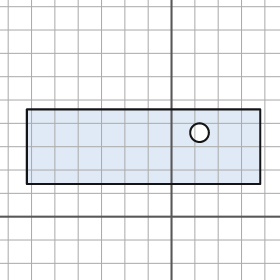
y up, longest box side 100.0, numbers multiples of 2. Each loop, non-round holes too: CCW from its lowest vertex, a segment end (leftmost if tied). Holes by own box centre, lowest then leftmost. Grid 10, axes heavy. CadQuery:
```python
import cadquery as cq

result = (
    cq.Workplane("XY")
    .moveTo(-62.0, 14.0)
    .lineTo(38.0, 14.0)
    .lineTo(38.0, 46.0)
    .lineTo(-62.0, 46.0)
    .close()
    .moveTo(12.0, 36.0)
    .circle(4.0)
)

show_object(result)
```